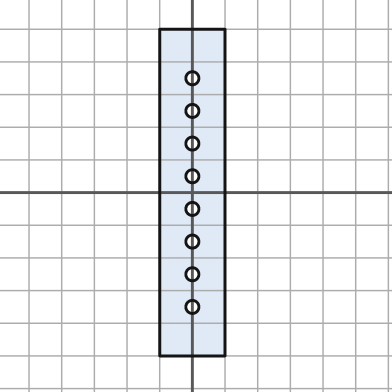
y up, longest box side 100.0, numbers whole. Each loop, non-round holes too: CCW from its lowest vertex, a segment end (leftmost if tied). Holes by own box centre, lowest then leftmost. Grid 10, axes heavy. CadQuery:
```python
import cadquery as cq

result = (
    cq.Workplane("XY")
    .moveTo(-10.0, -50.0)
    .lineTo(10.0, -50.0)
    .lineTo(10.0, 50.0)
    .lineTo(-10.0, 50.0)
    .close()
    .moveTo(0.0, -35.0)
    .circle(2.0)
    .moveTo(0.0, -25.0)
    .circle(2.0)
    .moveTo(0.0, -15.0)
    .circle(2.0)
    .moveTo(0.0, -5.0)
    .circle(2.0)
    .moveTo(0.0, 5.0)
    .circle(2.0)
    .moveTo(0.0, 15.0)
    .circle(2.0)
    .moveTo(0.0, 25.0)
    .circle(2.0)
    .moveTo(0.0, 35.0)
    .circle(2.0)
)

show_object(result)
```